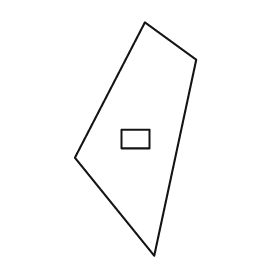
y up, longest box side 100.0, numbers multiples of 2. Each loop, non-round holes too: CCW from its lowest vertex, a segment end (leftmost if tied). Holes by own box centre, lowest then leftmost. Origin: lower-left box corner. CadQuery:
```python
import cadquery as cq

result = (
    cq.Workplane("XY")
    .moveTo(34.0, 0.0)
    .lineTo(52.0, 84.0)
    .lineTo(30.0, 100.0)
    .lineTo(0.0, 42.0)
    .close()
    .moveTo(20.0, 46.0)
    .lineTo(32.0, 46.0)
    .lineTo(32.0, 54.0)
    .lineTo(20.0, 54.0)
    .close()
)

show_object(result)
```